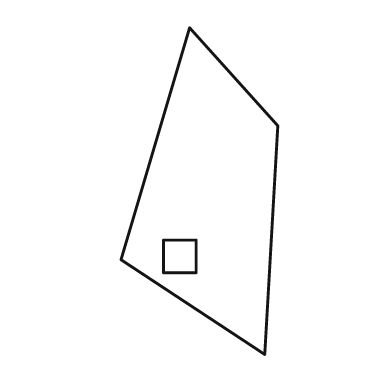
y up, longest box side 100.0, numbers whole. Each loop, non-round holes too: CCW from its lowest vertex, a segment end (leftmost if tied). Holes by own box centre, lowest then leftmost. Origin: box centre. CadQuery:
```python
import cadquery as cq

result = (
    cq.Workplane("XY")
    .moveTo(20.0, -50.0)
    .lineTo(24.0, 20.0)
    .lineTo(-3.0, 50.0)
    .lineTo(-24.0, -21.0)
    .close()
    .moveTo(-11.0, -25.0)
    .lineTo(-1.0, -25.0)
    .lineTo(-1.0, -15.0)
    .lineTo(-11.0, -15.0)
    .close()
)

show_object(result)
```